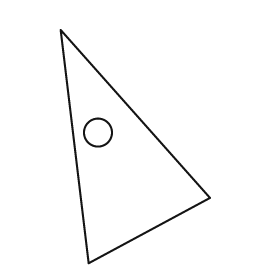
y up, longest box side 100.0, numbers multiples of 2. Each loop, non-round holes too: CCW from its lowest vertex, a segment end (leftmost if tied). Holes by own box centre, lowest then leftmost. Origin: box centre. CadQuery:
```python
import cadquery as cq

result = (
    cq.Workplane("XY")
    .moveTo(-20.0, -50.0)
    .lineTo(32.0, -22.0)
    .lineTo(-32.0, 50.0)
    .close()
    .moveTo(-16.0, 6.0)
    .circle(6.0)
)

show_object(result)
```